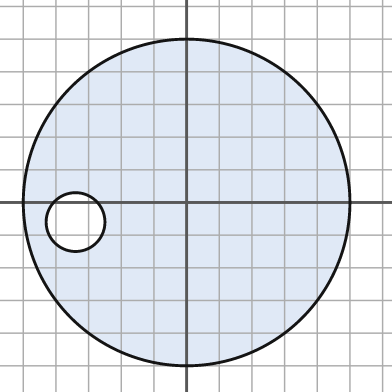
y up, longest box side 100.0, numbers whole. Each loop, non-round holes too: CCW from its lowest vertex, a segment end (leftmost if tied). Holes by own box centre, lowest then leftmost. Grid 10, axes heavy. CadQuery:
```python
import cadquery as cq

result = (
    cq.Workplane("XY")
    .moveTo(0.0, 0.0)
    .circle(50.0)
    .moveTo(-34.0, -6.0)
    .circle(9.0)
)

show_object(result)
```